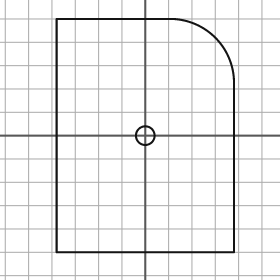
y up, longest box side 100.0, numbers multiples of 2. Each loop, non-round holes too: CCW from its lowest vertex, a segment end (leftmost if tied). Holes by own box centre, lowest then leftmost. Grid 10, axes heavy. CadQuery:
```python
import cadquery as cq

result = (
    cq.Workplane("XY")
    .moveTo(-38.0, -50.0)
    .lineTo(38.0, -50.0)
    .lineTo(38.0, 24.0)
    .threePointArc((30.0, 42.0), (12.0, 50.0))
    .lineTo(-38.0, 50.0)
    .close()
    .moveTo(0.0, 0.0)
    .circle(4.0)
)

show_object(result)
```